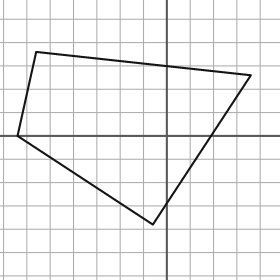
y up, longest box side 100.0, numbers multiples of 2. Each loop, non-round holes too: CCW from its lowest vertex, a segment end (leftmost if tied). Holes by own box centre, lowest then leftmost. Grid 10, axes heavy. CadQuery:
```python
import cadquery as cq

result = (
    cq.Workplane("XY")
    .moveTo(-6.0, -38.0)
    .lineTo(36.0, 26.0)
    .lineTo(-56.0, 36.0)
    .lineTo(-64.0, 0.0)
    .close()
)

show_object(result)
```